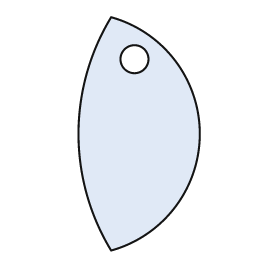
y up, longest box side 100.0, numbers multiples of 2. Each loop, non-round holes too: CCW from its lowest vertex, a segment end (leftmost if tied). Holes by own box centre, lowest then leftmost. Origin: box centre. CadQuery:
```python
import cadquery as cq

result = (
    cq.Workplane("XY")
    .moveTo(-12.0, -50.0)
    .threePointArc((26.0, 0.0), (-12.0, 50.0))
    .threePointArc((-26.0, 0.0), (-12.0, -50.0))
    .close()
    .moveTo(-2.0, 32.0)
    .circle(6.0)
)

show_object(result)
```